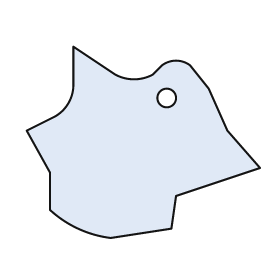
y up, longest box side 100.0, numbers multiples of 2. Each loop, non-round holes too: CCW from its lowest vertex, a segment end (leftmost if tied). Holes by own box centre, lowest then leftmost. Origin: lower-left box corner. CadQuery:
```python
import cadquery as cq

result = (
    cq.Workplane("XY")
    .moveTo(36.0, 0.0)
    .lineTo(62.0, 4.0)
    .lineTo(64.0, 18.0)
    .lineTo(100.0, 30.0)
    .lineTo(86.0, 46.0)
    .lineTo(78.0, 64.0)
    .lineTo(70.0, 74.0)
    .threePointArc((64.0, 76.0), (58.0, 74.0))
    .lineTo(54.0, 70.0)
    .threePointArc((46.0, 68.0), (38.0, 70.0))
    .lineTo(20.0, 82.0)
    .lineTo(20.0, 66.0)
    .threePointArc((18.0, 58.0), (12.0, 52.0))
    .lineTo(0.0, 46.0)
    .lineTo(10.0, 28.0)
    .lineTo(10.0, 12.0)
    .threePointArc((22.0, 4.0), (36.0, 0.0))
    .close()
    .moveTo(60.0, 60.0)
    .circle(4.0)
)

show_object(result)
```